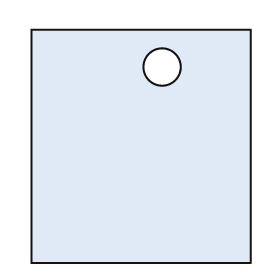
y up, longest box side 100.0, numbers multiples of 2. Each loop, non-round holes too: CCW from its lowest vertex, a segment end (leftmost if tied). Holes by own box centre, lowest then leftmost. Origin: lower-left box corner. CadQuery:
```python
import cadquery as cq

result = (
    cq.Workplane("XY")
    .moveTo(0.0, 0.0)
    .lineTo(94.0, 0.0)
    .lineTo(94.0, 100.0)
    .lineTo(0.0, 100.0)
    .close()
    .moveTo(56.0, 84.0)
    .circle(8.0)
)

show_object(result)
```